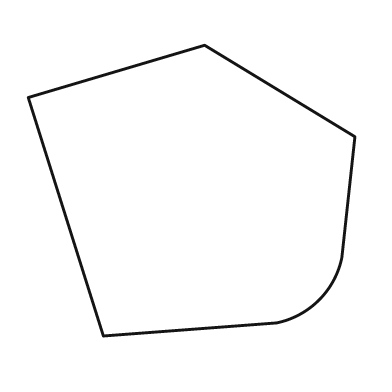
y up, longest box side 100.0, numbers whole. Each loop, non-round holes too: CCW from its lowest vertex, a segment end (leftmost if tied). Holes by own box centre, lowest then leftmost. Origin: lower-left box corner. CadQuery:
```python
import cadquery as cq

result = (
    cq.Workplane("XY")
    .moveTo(23.0, 0.0)
    .lineTo(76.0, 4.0)
    .threePointArc((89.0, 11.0), (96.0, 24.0))
    .lineTo(100.0, 61.0)
    .lineTo(54.0, 89.0)
    .lineTo(0.0, 73.0)
    .close()
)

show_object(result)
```